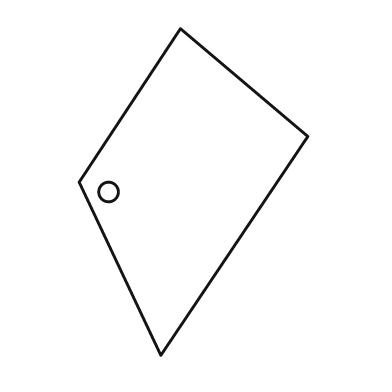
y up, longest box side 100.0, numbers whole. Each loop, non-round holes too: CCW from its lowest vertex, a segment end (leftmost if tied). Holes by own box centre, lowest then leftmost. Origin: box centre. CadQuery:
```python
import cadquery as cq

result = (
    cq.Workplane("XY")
    .moveTo(-10.0, -50.0)
    .lineTo(35.0, 17.0)
    .lineTo(-4.0, 50.0)
    .lineTo(-35.0, 3.0)
    .close()
    .moveTo(-26.0, 0.0)
    .circle(3.0)
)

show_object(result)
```